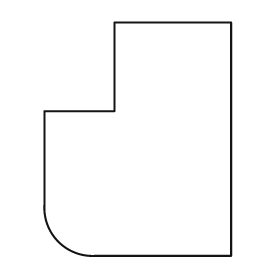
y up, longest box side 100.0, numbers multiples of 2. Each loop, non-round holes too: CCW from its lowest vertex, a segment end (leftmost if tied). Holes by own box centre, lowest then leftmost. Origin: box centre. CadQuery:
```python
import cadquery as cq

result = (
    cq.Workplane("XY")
    .moveTo(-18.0, -50.0)
    .lineTo(40.0, -50.0)
    .lineTo(40.0, 50.0)
    .lineTo(-10.0, 50.0)
    .lineTo(-10.0, 12.0)
    .lineTo(-40.0, 12.0)
    .lineTo(-40.0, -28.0)
    .threePointArc((-34.0, -44.0), (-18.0, -50.0))
    .close()
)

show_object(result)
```